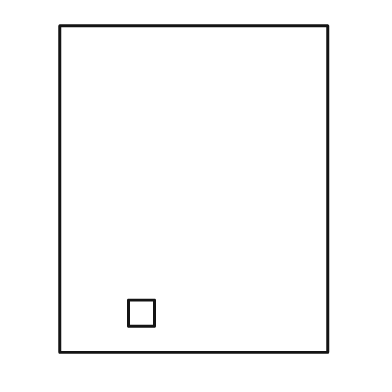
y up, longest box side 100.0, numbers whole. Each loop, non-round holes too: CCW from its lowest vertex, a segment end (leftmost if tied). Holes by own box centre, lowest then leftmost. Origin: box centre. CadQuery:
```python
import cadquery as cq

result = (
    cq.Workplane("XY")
    .moveTo(-41.0, -50.0)
    .lineTo(41.0, -50.0)
    .lineTo(41.0, 50.0)
    .lineTo(-41.0, 50.0)
    .close()
    .moveTo(-20.0, -42.0)
    .lineTo(-12.0, -42.0)
    .lineTo(-12.0, -34.0)
    .lineTo(-20.0, -34.0)
    .close()
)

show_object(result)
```